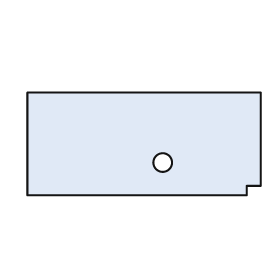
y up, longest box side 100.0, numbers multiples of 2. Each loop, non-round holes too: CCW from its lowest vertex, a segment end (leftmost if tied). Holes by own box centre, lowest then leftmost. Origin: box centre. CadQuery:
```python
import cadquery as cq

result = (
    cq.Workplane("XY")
    .moveTo(-50.0, -22.0)
    .lineTo(44.0, -22.0)
    .lineTo(44.0, -18.0)
    .lineTo(50.0, -18.0)
    .lineTo(50.0, 22.0)
    .lineTo(-50.0, 22.0)
    .close()
    .moveTo(8.0, -8.0)
    .circle(4.0)
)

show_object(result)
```